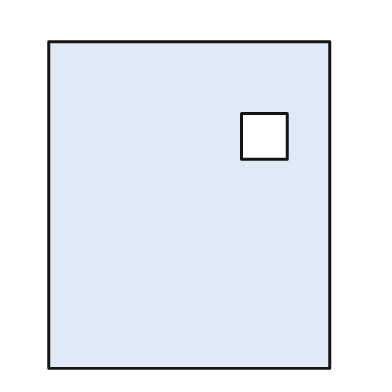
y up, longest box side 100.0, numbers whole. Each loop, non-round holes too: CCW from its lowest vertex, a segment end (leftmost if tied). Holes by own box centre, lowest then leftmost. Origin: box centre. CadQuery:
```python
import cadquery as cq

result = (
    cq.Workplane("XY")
    .moveTo(-43.0, -50.0)
    .lineTo(43.0, -50.0)
    .lineTo(43.0, 50.0)
    .lineTo(-43.0, 50.0)
    .close()
    .moveTo(16.0, 14.0)
    .lineTo(30.0, 14.0)
    .lineTo(30.0, 28.0)
    .lineTo(16.0, 28.0)
    .close()
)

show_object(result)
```